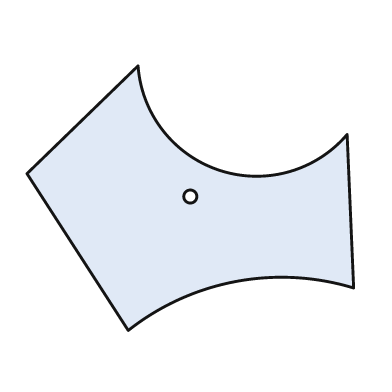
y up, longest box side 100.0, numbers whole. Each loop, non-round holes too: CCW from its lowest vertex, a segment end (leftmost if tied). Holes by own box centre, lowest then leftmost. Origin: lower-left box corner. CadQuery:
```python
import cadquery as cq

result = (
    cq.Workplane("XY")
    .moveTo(31.0, 0.0)
    .threePointArc((64.0, 15.0), (100.0, 13.0))
    .lineTo(98.0, 60.0)
    .threePointArc((59.0, 49.0), (34.0, 81.0))
    .lineTo(0.0, 48.0)
    .close()
    .moveTo(50.0, 41.0)
    .circle(2.0)
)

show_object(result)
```